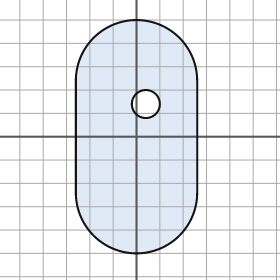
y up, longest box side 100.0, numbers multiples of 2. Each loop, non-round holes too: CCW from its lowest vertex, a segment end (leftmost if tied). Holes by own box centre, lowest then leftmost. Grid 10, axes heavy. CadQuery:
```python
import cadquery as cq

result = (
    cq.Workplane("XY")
    .moveTo(-26.0, -24.0)
    .threePointArc((0.0, -50.0), (26.0, -24.0))
    .lineTo(26.0, 24.0)
    .threePointArc((0.0, 50.0), (-26.0, 24.0))
    .close()
    .moveTo(4.0, 14.0)
    .circle(6.0)
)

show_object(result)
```